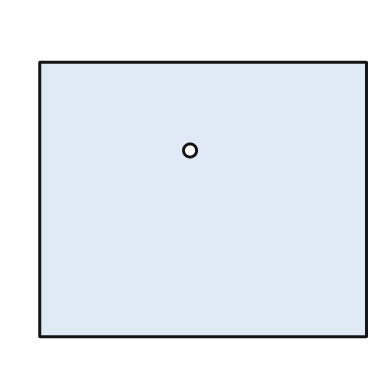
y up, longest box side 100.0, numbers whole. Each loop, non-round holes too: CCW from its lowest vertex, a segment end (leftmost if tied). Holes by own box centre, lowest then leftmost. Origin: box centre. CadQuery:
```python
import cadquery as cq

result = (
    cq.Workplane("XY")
    .moveTo(-50.0, -42.0)
    .lineTo(50.0, -42.0)
    .lineTo(50.0, 42.0)
    .lineTo(-50.0, 42.0)
    .close()
    .moveTo(-4.0, 15.0)
    .circle(2.0)
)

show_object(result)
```